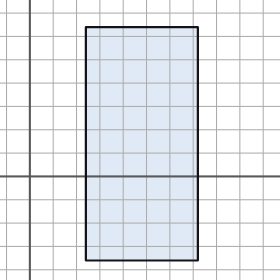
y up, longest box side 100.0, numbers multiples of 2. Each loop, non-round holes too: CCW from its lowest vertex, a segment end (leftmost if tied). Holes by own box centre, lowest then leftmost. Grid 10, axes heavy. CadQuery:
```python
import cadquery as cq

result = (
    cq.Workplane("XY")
    .moveTo(24.0, -36.0)
    .lineTo(72.0, -36.0)
    .lineTo(72.0, 64.0)
    .lineTo(24.0, 64.0)
    .close()
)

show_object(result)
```